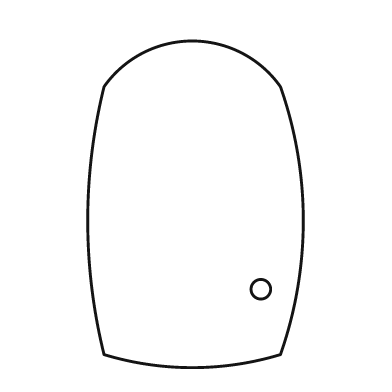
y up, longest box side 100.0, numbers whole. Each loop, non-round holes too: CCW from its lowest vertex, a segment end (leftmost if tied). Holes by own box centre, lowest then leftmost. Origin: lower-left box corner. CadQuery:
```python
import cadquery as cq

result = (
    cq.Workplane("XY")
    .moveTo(5.0, 4.0)
    .threePointArc((32.0, 0.0), (59.0, 4.0))
    .threePointArc((66.0, 45.0), (59.0, 86.0))
    .threePointArc((32.0, 100.0), (5.0, 86.0))
    .threePointArc((0.0, 45.0), (5.0, 4.0))
    .close()
    .moveTo(53.0, 24.0)
    .circle(3.0)
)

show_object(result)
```